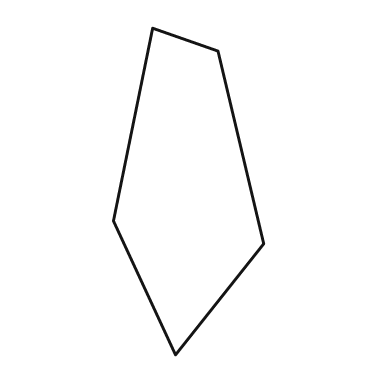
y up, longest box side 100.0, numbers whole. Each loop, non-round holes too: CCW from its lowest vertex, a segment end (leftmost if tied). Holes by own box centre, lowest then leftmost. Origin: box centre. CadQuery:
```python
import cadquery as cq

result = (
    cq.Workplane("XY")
    .moveTo(-4.0, -50.0)
    .lineTo(23.0, -16.0)
    .lineTo(9.0, 43.0)
    .lineTo(-11.0, 50.0)
    .lineTo(-23.0, -9.0)
    .close()
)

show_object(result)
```